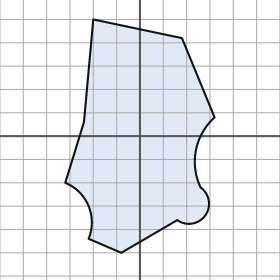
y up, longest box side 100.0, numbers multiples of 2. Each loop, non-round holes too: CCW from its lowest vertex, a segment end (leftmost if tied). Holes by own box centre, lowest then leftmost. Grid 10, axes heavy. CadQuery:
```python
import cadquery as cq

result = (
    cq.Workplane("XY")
    .moveTo(-8.0, -50.0)
    .lineTo(16.0, -36.0)
    .threePointArc((28.0, -34.0), (26.0, -22.0))
    .threePointArc((24.0, -6.0), (32.0, 8.0))
    .lineTo(18.0, 42.0)
    .lineTo(-20.0, 50.0)
    .lineTo(-24.0, 6.0)
    .lineTo(-32.0, -20.0)
    .threePointArc((-22.0, -30.0), (-22.0, -44.0))
    .close()
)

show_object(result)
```